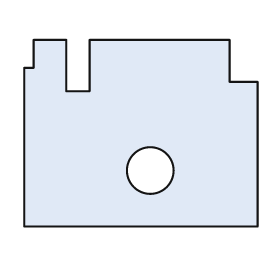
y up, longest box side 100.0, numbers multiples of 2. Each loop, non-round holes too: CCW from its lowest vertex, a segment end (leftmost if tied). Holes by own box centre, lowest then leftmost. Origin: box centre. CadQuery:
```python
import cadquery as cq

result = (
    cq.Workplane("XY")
    .moveTo(-50.0, -40.0)
    .lineTo(50.0, -40.0)
    .lineTo(50.0, 22.0)
    .lineTo(38.0, 22.0)
    .lineTo(38.0, 40.0)
    .lineTo(-22.0, 40.0)
    .lineTo(-22.0, 18.0)
    .lineTo(-32.0, 18.0)
    .lineTo(-32.0, 40.0)
    .lineTo(-46.0, 40.0)
    .lineTo(-46.0, 28.0)
    .lineTo(-50.0, 28.0)
    .close()
    .moveTo(4.0, -16.0)
    .circle(10.0)
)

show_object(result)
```